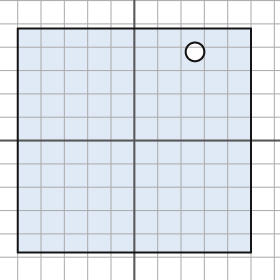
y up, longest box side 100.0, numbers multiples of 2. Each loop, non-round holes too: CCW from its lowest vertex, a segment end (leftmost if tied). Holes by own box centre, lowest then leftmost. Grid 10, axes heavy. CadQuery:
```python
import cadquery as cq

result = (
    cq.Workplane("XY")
    .moveTo(-50.0, -48.0)
    .lineTo(50.0, -48.0)
    .lineTo(50.0, 48.0)
    .lineTo(-50.0, 48.0)
    .close()
    .moveTo(26.0, 38.0)
    .circle(4.0)
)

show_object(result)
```